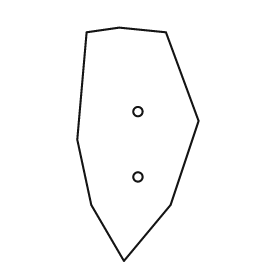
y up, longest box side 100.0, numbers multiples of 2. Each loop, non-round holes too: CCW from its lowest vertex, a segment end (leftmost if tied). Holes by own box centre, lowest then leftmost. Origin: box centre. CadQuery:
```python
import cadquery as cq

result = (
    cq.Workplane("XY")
    .moveTo(-6.0, -50.0)
    .lineTo(14.0, -26.0)
    .lineTo(26.0, 10.0)
    .lineTo(12.0, 48.0)
    .lineTo(-8.0, 50.0)
    .lineTo(-22.0, 48.0)
    .lineTo(-26.0, 2.0)
    .lineTo(-20.0, -26.0)
    .close()
    .moveTo(0.0, -14.0)
    .circle(2.0)
    .moveTo(0.0, 14.0)
    .circle(2.0)
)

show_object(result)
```